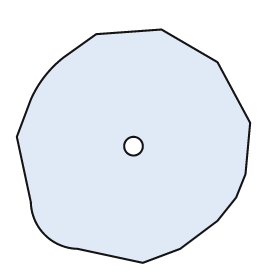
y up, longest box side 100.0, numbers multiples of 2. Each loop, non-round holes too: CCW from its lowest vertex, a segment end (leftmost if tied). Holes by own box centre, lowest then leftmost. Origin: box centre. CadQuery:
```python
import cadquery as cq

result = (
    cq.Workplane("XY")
    .moveTo(4.0, -50.0)
    .lineTo(20.0, -44.0)
    .lineTo(36.0, -32.0)
    .lineTo(44.0, -22.0)
    .lineTo(48.0, -12.0)
    .lineTo(50.0, 10.0)
    .lineTo(36.0, 36.0)
    .lineTo(12.0, 50.0)
    .lineTo(-16.0, 48.0)
    .lineTo(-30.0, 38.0)
    .threePointArc((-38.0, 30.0), (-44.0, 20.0))
    .lineTo(-50.0, 4.0)
    .lineTo(-44.0, -24.0)
    .threePointArc((-38.0, -38.0), (-24.0, -44.0))
    .close()
    .moveTo(0.0, 0.0)
    .circle(4.0)
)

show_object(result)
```